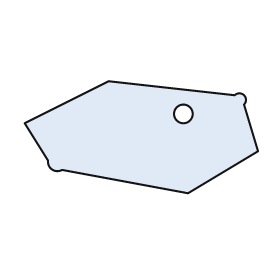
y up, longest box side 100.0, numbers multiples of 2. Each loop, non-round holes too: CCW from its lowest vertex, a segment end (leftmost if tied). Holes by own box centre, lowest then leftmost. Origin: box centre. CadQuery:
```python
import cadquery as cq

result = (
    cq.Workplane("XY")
    .moveTo(20.0, -24.0)
    .lineTo(50.0, -6.0)
    .lineTo(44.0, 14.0)
    .threePointArc((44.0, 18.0), (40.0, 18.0))
    .lineTo(-14.0, 24.0)
    .lineTo(-50.0, 6.0)
    .lineTo(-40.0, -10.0)
    .threePointArc((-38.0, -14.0), (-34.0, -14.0))
    .close()
    .moveTo(18.0, 10.0)
    .circle(4.0)
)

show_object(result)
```